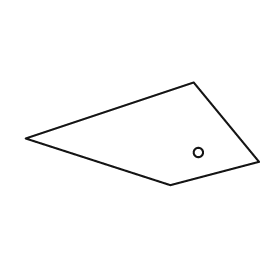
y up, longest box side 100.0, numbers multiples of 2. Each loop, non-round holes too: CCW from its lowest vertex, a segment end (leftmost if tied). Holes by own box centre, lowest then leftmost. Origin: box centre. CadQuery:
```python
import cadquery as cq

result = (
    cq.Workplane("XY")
    .moveTo(12.0, -22.0)
    .lineTo(50.0, -12.0)
    .lineTo(22.0, 22.0)
    .lineTo(-50.0, -2.0)
    .close()
    .moveTo(24.0, -8.0)
    .circle(2.0)
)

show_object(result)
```